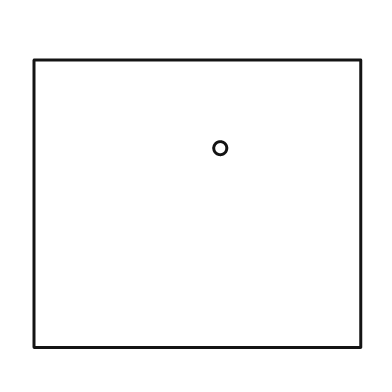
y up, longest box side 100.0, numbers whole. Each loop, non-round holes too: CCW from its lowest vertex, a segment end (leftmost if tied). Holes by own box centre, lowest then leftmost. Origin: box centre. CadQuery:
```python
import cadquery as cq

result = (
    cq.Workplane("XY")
    .moveTo(-50.0, -44.0)
    .lineTo(50.0, -44.0)
    .lineTo(50.0, 44.0)
    .lineTo(-50.0, 44.0)
    .close()
    .moveTo(7.0, 17.0)
    .circle(2.0)
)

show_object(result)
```